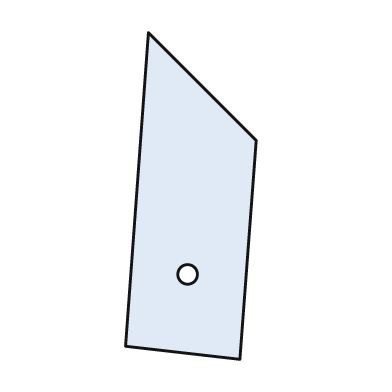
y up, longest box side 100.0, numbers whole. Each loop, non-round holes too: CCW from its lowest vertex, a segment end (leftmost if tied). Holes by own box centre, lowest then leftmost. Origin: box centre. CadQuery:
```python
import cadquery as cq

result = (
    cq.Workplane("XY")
    .moveTo(15.0, -50.0)
    .lineTo(20.0, 17.0)
    .lineTo(-13.0, 50.0)
    .lineTo(-20.0, -46.0)
    .close()
    .moveTo(-1.0, -24.0)
    .circle(3.0)
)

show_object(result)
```